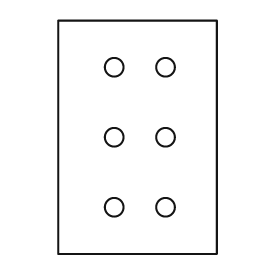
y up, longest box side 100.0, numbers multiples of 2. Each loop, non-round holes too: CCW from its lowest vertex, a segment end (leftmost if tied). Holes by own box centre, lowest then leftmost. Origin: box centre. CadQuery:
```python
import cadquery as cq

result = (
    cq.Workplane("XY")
    .moveTo(-34.0, -50.0)
    .lineTo(34.0, -50.0)
    .lineTo(34.0, 50.0)
    .lineTo(-34.0, 50.0)
    .close()
    .moveTo(-10.0, -30.0)
    .circle(4.0)
    .moveTo(12.0, -30.0)
    .circle(4.0)
    .moveTo(-10.0, 0.0)
    .circle(4.0)
    .moveTo(12.0, 0.0)
    .circle(4.0)
    .moveTo(-10.0, 30.0)
    .circle(4.0)
    .moveTo(12.0, 30.0)
    .circle(4.0)
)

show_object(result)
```